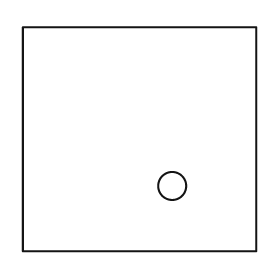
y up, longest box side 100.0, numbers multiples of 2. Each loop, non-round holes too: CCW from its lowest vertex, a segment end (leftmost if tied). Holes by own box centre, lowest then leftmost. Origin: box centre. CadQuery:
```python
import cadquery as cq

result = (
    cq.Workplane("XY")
    .moveTo(-50.0, -48.0)
    .lineTo(50.0, -48.0)
    .lineTo(50.0, 48.0)
    .lineTo(-50.0, 48.0)
    .close()
    .moveTo(14.0, -20.0)
    .circle(6.0)
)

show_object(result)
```